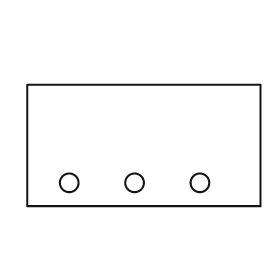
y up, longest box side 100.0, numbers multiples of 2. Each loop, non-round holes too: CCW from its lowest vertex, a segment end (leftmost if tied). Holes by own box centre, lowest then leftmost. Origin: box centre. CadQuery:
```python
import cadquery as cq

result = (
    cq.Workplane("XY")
    .moveTo(-50.0, -26.0)
    .lineTo(50.0, -26.0)
    .lineTo(50.0, 26.0)
    .lineTo(-50.0, 26.0)
    .close()
    .moveTo(-32.0, -16.0)
    .circle(4.0)
    .moveTo(-4.0, -16.0)
    .circle(4.0)
    .moveTo(24.0, -16.0)
    .circle(4.0)
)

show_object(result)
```